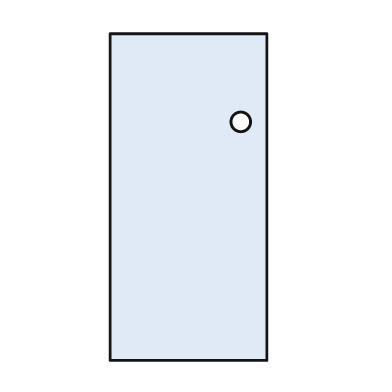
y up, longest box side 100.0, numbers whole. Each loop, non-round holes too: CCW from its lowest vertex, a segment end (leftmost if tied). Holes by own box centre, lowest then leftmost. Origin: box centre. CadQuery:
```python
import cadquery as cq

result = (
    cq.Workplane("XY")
    .moveTo(-24.0, -50.0)
    .lineTo(24.0, -50.0)
    .lineTo(24.0, 50.0)
    .lineTo(-24.0, 50.0)
    .close()
    .moveTo(16.0, 23.0)
    .circle(3.0)
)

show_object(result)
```